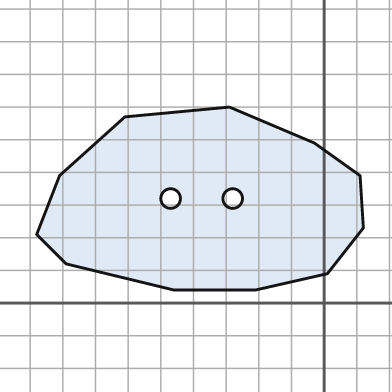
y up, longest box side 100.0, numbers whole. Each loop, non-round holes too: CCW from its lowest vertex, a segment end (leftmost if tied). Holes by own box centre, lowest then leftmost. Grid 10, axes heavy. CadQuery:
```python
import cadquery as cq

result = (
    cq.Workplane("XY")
    .moveTo(-46.0, 4.0)
    .lineTo(-21.0, 4.0)
    .lineTo(1.0, 9.0)
    .lineTo(12.0, 23.0)
    .lineTo(11.0, 39.0)
    .lineTo(-3.0, 49.0)
    .lineTo(-29.0, 60.0)
    .lineTo(-61.0, 57.0)
    .lineTo(-81.0, 39.0)
    .lineTo(-88.0, 21.0)
    .lineTo(-79.0, 12.0)
    .close()
    .moveTo(-47.0, 32.0)
    .circle(3.0)
    .moveTo(-28.0, 32.0)
    .circle(3.0)
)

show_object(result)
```